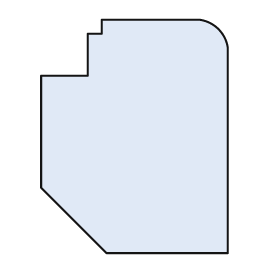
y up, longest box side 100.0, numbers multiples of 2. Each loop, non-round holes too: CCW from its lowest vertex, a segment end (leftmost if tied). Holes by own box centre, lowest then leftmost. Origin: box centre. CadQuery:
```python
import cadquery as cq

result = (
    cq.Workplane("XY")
    .moveTo(-12.0, -50.0)
    .lineTo(40.0, -50.0)
    .lineTo(40.0, 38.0)
    .threePointArc((36.0, 46.0), (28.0, 50.0))
    .lineTo(-14.0, 50.0)
    .lineTo(-14.0, 44.0)
    .lineTo(-20.0, 44.0)
    .lineTo(-20.0, 26.0)
    .lineTo(-40.0, 26.0)
    .lineTo(-40.0, -22.0)
    .close()
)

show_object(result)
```